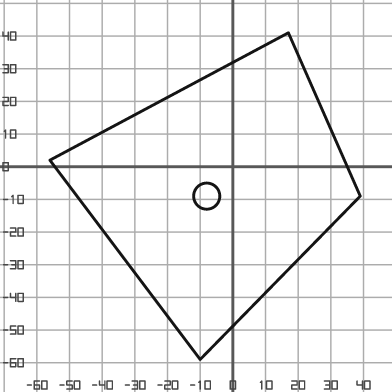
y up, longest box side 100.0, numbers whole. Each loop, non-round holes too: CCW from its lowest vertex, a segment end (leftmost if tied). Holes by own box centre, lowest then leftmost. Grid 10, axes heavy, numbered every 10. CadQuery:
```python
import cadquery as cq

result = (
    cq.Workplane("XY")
    .moveTo(-10.0, -59.0)
    .lineTo(39.0, -9.0)
    .lineTo(17.0, 41.0)
    .lineTo(-56.0, 2.0)
    .close()
    .moveTo(-8.0, -9.0)
    .circle(4.0)
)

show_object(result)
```